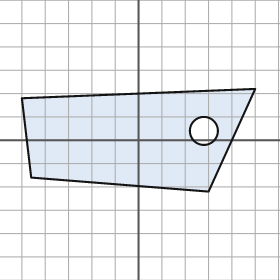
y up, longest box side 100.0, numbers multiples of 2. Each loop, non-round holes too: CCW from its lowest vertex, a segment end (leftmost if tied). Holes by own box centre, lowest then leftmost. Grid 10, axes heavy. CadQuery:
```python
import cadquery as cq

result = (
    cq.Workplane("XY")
    .moveTo(30.0, -22.0)
    .lineTo(50.0, 22.0)
    .lineTo(-50.0, 18.0)
    .lineTo(-46.0, -16.0)
    .close()
    .moveTo(28.0, 4.0)
    .circle(6.0)
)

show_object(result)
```